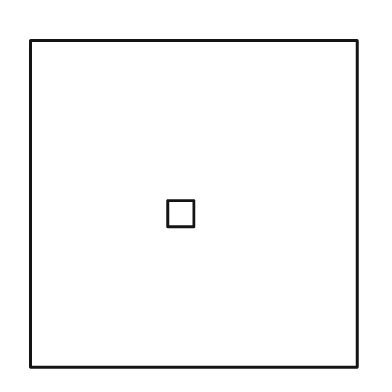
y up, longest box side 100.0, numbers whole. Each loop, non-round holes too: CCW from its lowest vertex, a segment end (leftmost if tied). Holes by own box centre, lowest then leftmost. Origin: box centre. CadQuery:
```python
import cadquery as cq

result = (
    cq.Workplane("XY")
    .moveTo(-50.0, -50.0)
    .lineTo(50.0, -50.0)
    .lineTo(50.0, 50.0)
    .lineTo(-50.0, 50.0)
    .close()
    .moveTo(-8.0, -7.0)
    .lineTo(0.0, -7.0)
    .lineTo(0.0, 1.0)
    .lineTo(-8.0, 1.0)
    .close()
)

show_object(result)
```